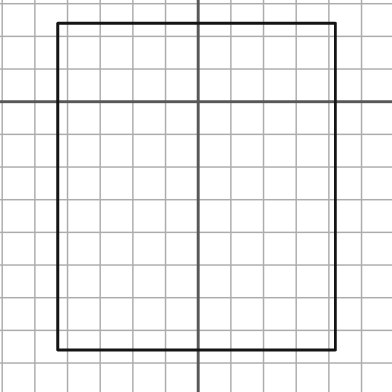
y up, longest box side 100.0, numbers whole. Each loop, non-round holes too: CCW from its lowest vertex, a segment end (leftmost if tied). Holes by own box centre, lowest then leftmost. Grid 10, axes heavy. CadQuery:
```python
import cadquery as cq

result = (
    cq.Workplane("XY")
    .moveTo(-43.0, -76.0)
    .lineTo(42.0, -76.0)
    .lineTo(42.0, 24.0)
    .lineTo(-43.0, 24.0)
    .close()
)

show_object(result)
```